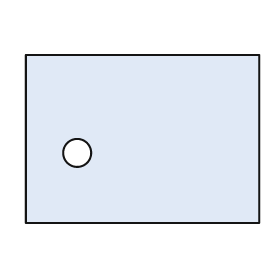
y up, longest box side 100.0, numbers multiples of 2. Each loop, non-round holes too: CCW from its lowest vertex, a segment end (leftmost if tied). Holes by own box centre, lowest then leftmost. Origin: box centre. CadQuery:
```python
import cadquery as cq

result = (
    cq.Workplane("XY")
    .moveTo(-50.0, -36.0)
    .lineTo(50.0, -36.0)
    .lineTo(50.0, 36.0)
    .lineTo(-50.0, 36.0)
    .close()
    .moveTo(-28.0, -6.0)
    .circle(6.0)
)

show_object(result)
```